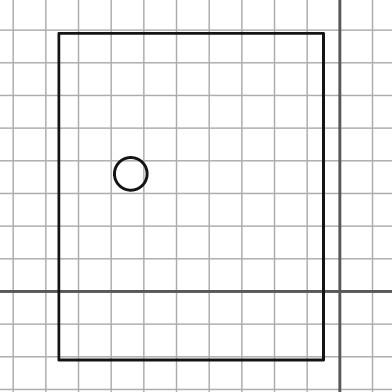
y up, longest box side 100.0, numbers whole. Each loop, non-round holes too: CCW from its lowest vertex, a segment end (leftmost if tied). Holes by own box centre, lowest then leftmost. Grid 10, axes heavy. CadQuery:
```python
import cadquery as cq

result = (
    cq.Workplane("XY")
    .moveTo(-86.0, -21.0)
    .lineTo(-5.0, -21.0)
    .lineTo(-5.0, 79.0)
    .lineTo(-86.0, 79.0)
    .close()
    .moveTo(-64.0, 36.0)
    .circle(5.0)
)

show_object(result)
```